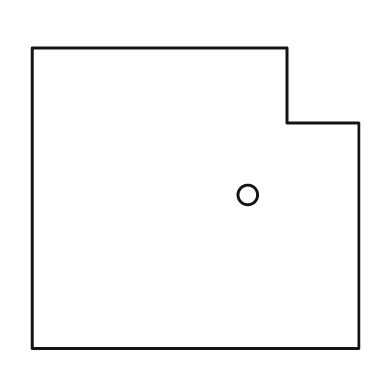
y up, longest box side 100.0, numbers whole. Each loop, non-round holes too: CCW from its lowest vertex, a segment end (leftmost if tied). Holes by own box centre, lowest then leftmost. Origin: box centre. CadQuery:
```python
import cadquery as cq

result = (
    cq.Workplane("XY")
    .moveTo(-50.0, -46.0)
    .lineTo(50.0, -46.0)
    .lineTo(50.0, 23.0)
    .lineTo(28.0, 23.0)
    .lineTo(28.0, 46.0)
    .lineTo(-50.0, 46.0)
    .close()
    .moveTo(16.0, 1.0)
    .circle(3.0)
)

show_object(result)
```